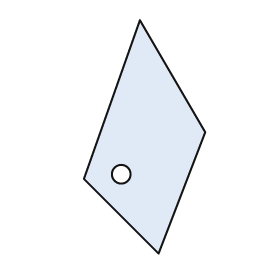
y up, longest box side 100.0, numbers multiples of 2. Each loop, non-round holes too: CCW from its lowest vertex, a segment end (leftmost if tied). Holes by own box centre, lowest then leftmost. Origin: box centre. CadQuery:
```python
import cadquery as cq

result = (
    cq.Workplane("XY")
    .moveTo(6.0, -50.0)
    .lineTo(26.0, 2.0)
    .lineTo(-2.0, 50.0)
    .lineTo(-26.0, -18.0)
    .close()
    .moveTo(-10.0, -16.0)
    .circle(4.0)
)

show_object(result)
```